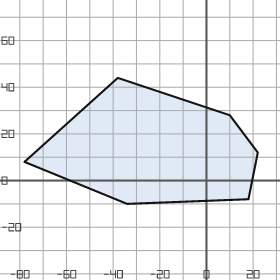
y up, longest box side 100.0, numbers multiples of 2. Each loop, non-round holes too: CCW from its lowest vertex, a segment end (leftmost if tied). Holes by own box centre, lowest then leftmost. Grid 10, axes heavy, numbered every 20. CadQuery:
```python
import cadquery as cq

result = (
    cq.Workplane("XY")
    .moveTo(-34.0, -10.0)
    .lineTo(18.0, -8.0)
    .lineTo(22.0, 12.0)
    .lineTo(10.0, 28.0)
    .lineTo(-38.0, 44.0)
    .lineTo(-78.0, 8.0)
    .close()
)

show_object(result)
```